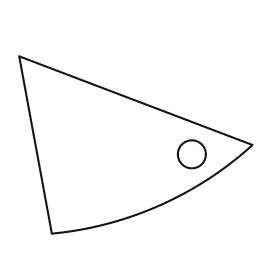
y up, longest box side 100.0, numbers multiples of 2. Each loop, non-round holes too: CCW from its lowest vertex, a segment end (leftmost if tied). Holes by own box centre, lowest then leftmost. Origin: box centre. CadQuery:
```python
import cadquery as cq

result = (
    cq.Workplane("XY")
    .moveTo(-36.0, -38.0)
    .threePointArc((10.0, -26.0), (50.0, 0.0))
    .lineTo(-50.0, 38.0)
    .close()
    .moveTo(24.0, -4.0)
    .circle(6.0)
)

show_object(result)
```